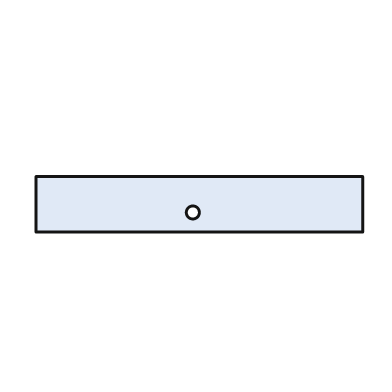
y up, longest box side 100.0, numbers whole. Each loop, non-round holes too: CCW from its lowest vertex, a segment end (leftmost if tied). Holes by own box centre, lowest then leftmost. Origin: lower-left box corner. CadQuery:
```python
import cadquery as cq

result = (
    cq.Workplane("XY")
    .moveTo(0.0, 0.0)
    .lineTo(100.0, 0.0)
    .lineTo(100.0, 17.0)
    .lineTo(0.0, 17.0)
    .close()
    .moveTo(48.0, 6.0)
    .circle(2.0)
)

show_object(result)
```